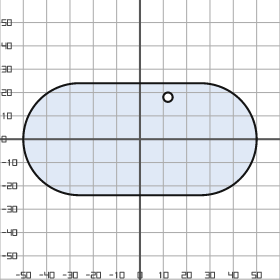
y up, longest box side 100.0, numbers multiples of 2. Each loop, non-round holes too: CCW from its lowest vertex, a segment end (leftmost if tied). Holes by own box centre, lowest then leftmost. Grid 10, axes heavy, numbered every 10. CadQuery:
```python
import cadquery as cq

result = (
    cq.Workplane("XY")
    .moveTo(-26.0, -24.0)
    .lineTo(26.0, -24.0)
    .threePointArc((50.0, 0.0), (26.0, 24.0))
    .lineTo(-26.0, 24.0)
    .threePointArc((-50.0, 0.0), (-26.0, -24.0))
    .close()
    .moveTo(12.0, 18.0)
    .circle(2.0)
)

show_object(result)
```